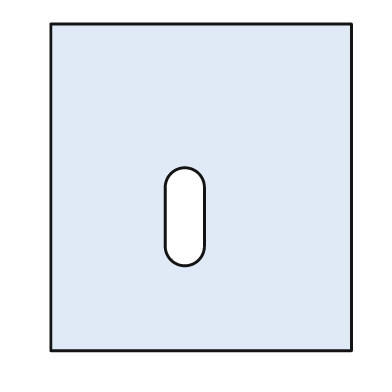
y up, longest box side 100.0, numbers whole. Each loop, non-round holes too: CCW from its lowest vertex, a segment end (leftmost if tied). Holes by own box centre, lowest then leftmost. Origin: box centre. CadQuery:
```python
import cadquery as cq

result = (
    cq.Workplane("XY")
    .moveTo(-46.0, -50.0)
    .lineTo(46.0, -50.0)
    .lineTo(46.0, 50.0)
    .lineTo(-46.0, 50.0)
    .close()
    .moveTo(-11.0, -18.0)
    .threePointArc((-5.0, -24.0), (1.0, -18.0))
    .lineTo(1.0, 0.0)
    .threePointArc((-5.0, 6.0), (-11.0, 0.0))
    .close()
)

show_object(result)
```